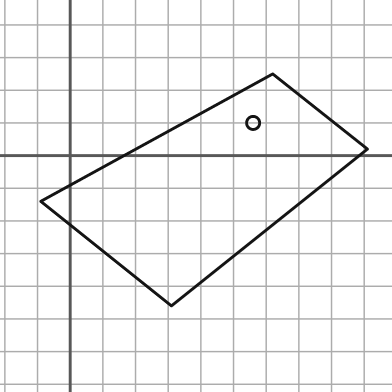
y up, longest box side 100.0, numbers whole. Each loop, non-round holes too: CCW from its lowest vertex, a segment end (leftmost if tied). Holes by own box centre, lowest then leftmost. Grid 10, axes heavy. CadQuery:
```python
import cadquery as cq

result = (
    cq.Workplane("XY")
    .moveTo(31.0, -46.0)
    .lineTo(91.0, 2.0)
    .lineTo(62.0, 25.0)
    .lineTo(-9.0, -14.0)
    .close()
    .moveTo(56.0, 10.0)
    .circle(2.0)
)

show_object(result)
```